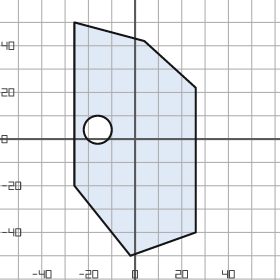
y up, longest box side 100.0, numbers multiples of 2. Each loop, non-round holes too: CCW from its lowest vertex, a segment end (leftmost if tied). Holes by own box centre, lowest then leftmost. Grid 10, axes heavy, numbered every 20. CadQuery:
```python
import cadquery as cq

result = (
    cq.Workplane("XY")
    .moveTo(-2.0, -50.0)
    .lineTo(26.0, -40.0)
    .lineTo(26.0, 22.0)
    .lineTo(4.0, 42.0)
    .lineTo(-26.0, 50.0)
    .lineTo(-26.0, -20.0)
    .close()
    .moveTo(-16.0, 4.0)
    .circle(6.0)
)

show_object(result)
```